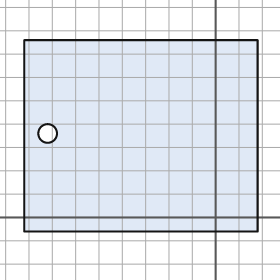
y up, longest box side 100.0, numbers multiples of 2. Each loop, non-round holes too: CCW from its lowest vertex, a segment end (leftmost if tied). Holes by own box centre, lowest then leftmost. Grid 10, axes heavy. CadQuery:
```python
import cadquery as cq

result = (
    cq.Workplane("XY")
    .moveTo(-82.0, -6.0)
    .lineTo(18.0, -6.0)
    .lineTo(18.0, 76.0)
    .lineTo(-82.0, 76.0)
    .close()
    .moveTo(-72.0, 36.0)
    .circle(4.0)
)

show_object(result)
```